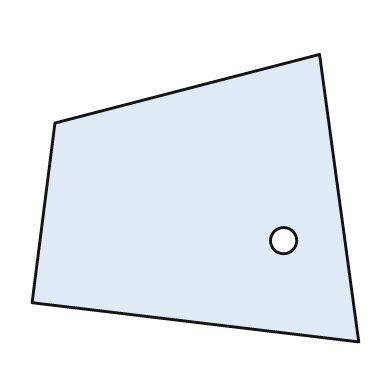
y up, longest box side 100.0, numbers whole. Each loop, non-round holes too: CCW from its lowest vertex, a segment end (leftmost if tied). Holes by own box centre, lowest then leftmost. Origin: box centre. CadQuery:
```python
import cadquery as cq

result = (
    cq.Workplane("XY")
    .moveTo(50.0, -44.0)
    .lineTo(38.0, 44.0)
    .lineTo(-43.0, 23.0)
    .lineTo(-50.0, -32.0)
    .close()
    .moveTo(27.0, -13.0)
    .circle(4.0)
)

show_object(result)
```